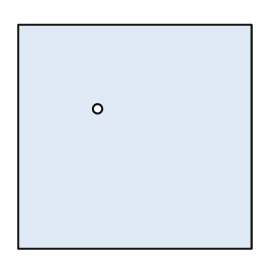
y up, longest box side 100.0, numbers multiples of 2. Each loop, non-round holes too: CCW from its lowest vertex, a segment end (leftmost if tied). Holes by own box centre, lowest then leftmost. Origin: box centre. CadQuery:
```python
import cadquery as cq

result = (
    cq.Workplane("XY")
    .moveTo(-50.0, -48.0)
    .lineTo(50.0, -48.0)
    .lineTo(50.0, 48.0)
    .lineTo(-50.0, 48.0)
    .close()
    .moveTo(-16.0, 12.0)
    .circle(2.0)
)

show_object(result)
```